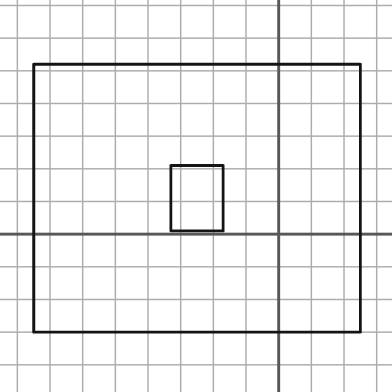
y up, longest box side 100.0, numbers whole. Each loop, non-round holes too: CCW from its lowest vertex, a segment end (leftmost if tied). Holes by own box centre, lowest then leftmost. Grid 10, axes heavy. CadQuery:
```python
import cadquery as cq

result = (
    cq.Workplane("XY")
    .moveTo(-75.0, -30.0)
    .lineTo(25.0, -30.0)
    .lineTo(25.0, 52.0)
    .lineTo(-75.0, 52.0)
    .close()
    .moveTo(-33.0, 1.0)
    .lineTo(-17.0, 1.0)
    .lineTo(-17.0, 21.0)
    .lineTo(-33.0, 21.0)
    .close()
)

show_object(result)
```